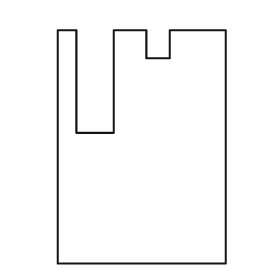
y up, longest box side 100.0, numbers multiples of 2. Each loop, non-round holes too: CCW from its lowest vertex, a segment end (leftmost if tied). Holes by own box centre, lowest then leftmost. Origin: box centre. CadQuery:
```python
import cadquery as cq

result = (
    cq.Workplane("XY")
    .moveTo(-36.0, -50.0)
    .lineTo(36.0, -50.0)
    .lineTo(36.0, 50.0)
    .lineTo(12.0, 50.0)
    .lineTo(12.0, 38.0)
    .lineTo(2.0, 38.0)
    .lineTo(2.0, 50.0)
    .lineTo(-12.0, 50.0)
    .lineTo(-12.0, 6.0)
    .lineTo(-28.0, 6.0)
    .lineTo(-28.0, 50.0)
    .lineTo(-36.0, 50.0)
    .close()
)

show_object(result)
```